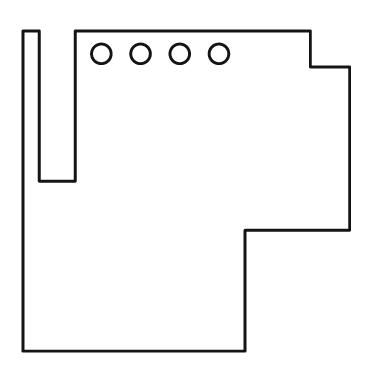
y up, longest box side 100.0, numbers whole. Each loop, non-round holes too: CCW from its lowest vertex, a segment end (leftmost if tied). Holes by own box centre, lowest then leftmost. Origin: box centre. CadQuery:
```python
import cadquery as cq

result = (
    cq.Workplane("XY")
    .moveTo(-50.0, -49.0)
    .lineTo(18.0, -49.0)
    .lineTo(18.0, -12.0)
    .lineTo(50.0, -12.0)
    .lineTo(50.0, 38.0)
    .lineTo(38.0, 38.0)
    .lineTo(38.0, 49.0)
    .lineTo(-34.0, 49.0)
    .lineTo(-34.0, 3.0)
    .lineTo(-45.0, 3.0)
    .lineTo(-45.0, 49.0)
    .lineTo(-50.0, 49.0)
    .close()
    .moveTo(-26.0, 42.0)
    .circle(3.0)
    .moveTo(-14.0, 42.0)
    .circle(3.0)
    .moveTo(-2.0, 42.0)
    .circle(3.0)
    .moveTo(10.0, 42.0)
    .circle(3.0)
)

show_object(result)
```